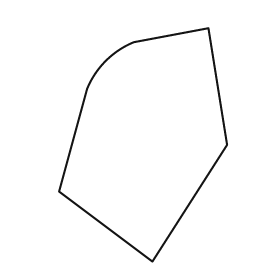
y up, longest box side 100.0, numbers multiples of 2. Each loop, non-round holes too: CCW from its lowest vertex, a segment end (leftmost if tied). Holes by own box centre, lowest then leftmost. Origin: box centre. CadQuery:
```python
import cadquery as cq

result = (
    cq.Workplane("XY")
    .moveTo(4.0, -50.0)
    .lineTo(36.0, 0.0)
    .lineTo(28.0, 50.0)
    .lineTo(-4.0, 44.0)
    .threePointArc((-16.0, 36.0), (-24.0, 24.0))
    .lineTo(-36.0, -20.0)
    .close()
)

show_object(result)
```